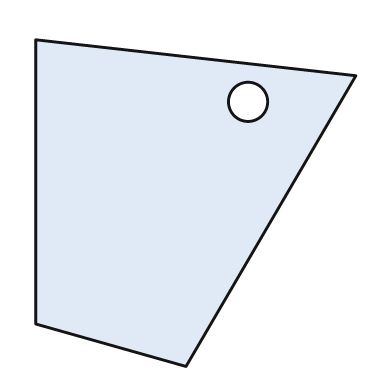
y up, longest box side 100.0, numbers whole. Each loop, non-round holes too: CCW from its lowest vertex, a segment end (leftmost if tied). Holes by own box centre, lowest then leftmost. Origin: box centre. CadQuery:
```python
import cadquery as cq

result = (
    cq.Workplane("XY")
    .moveTo(-3.0, -50.0)
    .lineTo(49.0, 39.0)
    .lineTo(-49.0, 50.0)
    .lineTo(-49.0, -37.0)
    .close()
    .moveTo(16.0, 31.0)
    .circle(6.0)
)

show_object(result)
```